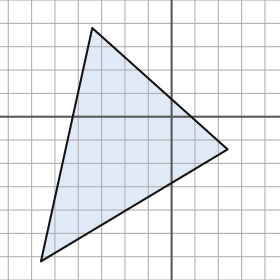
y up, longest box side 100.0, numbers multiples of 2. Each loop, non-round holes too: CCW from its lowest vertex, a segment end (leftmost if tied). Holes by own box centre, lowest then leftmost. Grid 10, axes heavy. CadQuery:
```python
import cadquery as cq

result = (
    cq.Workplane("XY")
    .moveTo(-56.0, -62.0)
    .lineTo(24.0, -14.0)
    .lineTo(-34.0, 38.0)
    .close()
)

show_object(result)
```